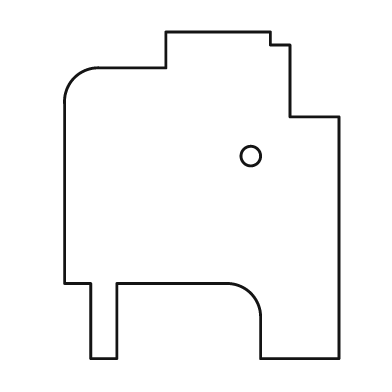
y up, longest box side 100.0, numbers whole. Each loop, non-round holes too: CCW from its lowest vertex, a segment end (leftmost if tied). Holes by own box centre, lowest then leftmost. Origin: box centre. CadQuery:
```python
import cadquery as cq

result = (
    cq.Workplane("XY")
    .moveTo(-34.0, -50.0)
    .lineTo(-26.0, -50.0)
    .lineTo(-26.0, -27.0)
    .lineTo(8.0, -27.0)
    .threePointArc((15.0, -30.0), (18.0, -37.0))
    .lineTo(18.0, -50.0)
    .lineTo(42.0, -50.0)
    .lineTo(42.0, 24.0)
    .lineTo(27.0, 24.0)
    .lineTo(27.0, 46.0)
    .lineTo(21.0, 46.0)
    .lineTo(21.0, 50.0)
    .lineTo(-11.0, 50.0)
    .lineTo(-11.0, 39.0)
    .lineTo(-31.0, 39.0)
    .threePointArc((-39.0, 36.0), (-42.0, 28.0))
    .lineTo(-42.0, -27.0)
    .lineTo(-34.0, -27.0)
    .close()
    .moveTo(15.0, 12.0)
    .circle(3.0)
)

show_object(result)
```